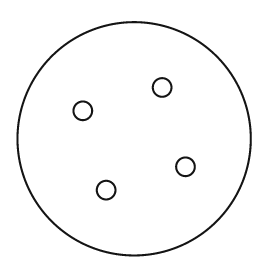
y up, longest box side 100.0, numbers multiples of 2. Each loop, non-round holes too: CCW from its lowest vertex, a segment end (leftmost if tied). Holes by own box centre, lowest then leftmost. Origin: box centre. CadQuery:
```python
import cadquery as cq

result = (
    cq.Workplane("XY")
    .moveTo(0.0, 0.0)
    .circle(50.0)
    .moveTo(-12.0, -22.0)
    .circle(4.0)
    .moveTo(22.0, -12.0)
    .circle(4.0)
    .moveTo(-22.0, 12.0)
    .circle(4.0)
    .moveTo(12.0, 22.0)
    .circle(4.0)
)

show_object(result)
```